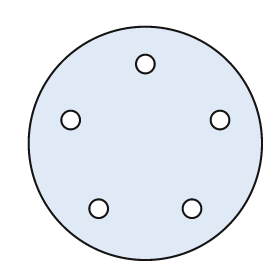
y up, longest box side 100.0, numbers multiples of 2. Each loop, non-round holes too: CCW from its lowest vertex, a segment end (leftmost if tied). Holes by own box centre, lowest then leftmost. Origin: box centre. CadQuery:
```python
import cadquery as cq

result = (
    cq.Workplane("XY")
    .moveTo(0.0, 0.0)
    .circle(50.0)
    .moveTo(-20.0, -28.0)
    .circle(4.0)
    .moveTo(20.0, -28.0)
    .circle(4.0)
    .moveTo(-32.0, 10.0)
    .circle(4.0)
    .moveTo(32.0, 10.0)
    .circle(4.0)
    .moveTo(0.0, 34.0)
    .circle(4.0)
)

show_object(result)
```